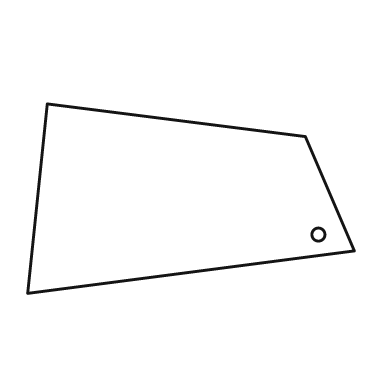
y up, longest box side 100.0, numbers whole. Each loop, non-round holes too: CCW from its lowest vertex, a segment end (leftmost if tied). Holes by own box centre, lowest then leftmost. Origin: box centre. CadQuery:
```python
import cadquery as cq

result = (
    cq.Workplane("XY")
    .moveTo(-50.0, -29.0)
    .lineTo(50.0, -16.0)
    .lineTo(35.0, 19.0)
    .lineTo(-44.0, 29.0)
    .close()
    .moveTo(39.0, -11.0)
    .circle(2.0)
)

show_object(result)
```